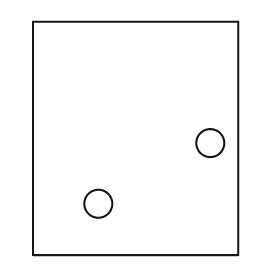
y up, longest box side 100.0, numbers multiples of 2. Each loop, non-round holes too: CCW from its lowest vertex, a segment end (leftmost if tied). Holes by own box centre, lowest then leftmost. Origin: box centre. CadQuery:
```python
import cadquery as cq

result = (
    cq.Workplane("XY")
    .moveTo(-44.0, -50.0)
    .lineTo(44.0, -50.0)
    .lineTo(44.0, 50.0)
    .lineTo(-44.0, 50.0)
    .close()
    .moveTo(-16.0, -28.0)
    .circle(6.0)
    .moveTo(32.0, -2.0)
    .circle(6.0)
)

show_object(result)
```